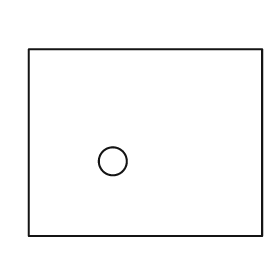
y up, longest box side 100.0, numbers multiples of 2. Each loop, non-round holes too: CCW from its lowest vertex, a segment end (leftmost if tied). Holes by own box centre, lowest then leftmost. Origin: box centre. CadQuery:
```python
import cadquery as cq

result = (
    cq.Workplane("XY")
    .moveTo(-50.0, -40.0)
    .lineTo(50.0, -40.0)
    .lineTo(50.0, 40.0)
    .lineTo(-50.0, 40.0)
    .close()
    .moveTo(-14.0, -8.0)
    .circle(6.0)
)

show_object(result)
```